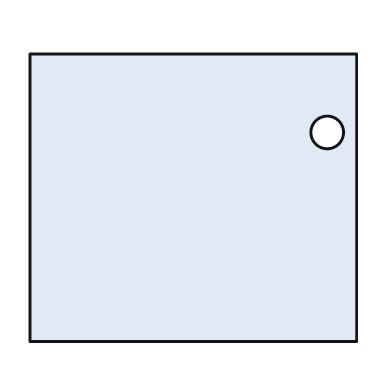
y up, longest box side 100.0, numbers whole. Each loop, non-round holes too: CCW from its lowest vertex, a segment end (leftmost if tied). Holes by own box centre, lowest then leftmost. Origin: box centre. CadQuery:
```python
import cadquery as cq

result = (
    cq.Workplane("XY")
    .moveTo(-50.0, -44.0)
    .lineTo(50.0, -44.0)
    .lineTo(50.0, 44.0)
    .lineTo(-50.0, 44.0)
    .close()
    .moveTo(41.0, 20.0)
    .circle(5.0)
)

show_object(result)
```